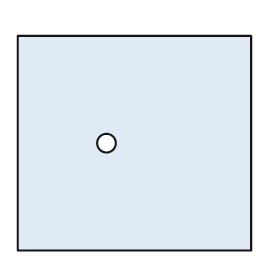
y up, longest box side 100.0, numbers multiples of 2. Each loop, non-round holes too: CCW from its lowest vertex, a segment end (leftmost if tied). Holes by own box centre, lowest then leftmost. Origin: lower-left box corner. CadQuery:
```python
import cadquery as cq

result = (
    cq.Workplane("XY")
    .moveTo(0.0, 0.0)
    .lineTo(100.0, 0.0)
    .lineTo(100.0, 92.0)
    .lineTo(0.0, 92.0)
    .close()
    .moveTo(38.0, 46.0)
    .circle(4.0)
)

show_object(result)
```